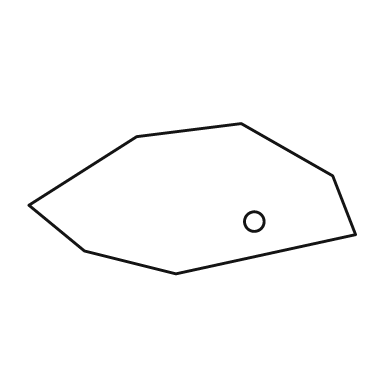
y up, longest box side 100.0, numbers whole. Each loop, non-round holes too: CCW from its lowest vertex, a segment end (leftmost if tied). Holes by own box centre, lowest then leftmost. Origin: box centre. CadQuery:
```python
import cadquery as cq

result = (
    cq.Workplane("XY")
    .moveTo(-5.0, -23.0)
    .lineTo(50.0, -11.0)
    .lineTo(43.0, 7.0)
    .lineTo(15.0, 23.0)
    .lineTo(-17.0, 19.0)
    .lineTo(-50.0, -2.0)
    .lineTo(-33.0, -16.0)
    .close()
    .moveTo(19.0, -7.0)
    .circle(3.0)
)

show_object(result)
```